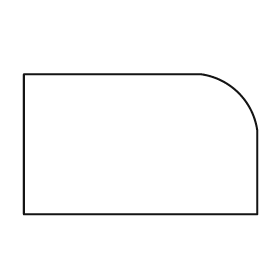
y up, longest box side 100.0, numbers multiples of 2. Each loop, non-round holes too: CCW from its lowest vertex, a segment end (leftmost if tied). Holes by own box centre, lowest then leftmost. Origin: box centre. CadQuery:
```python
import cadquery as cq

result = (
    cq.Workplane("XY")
    .moveTo(-50.0, -30.0)
    .lineTo(50.0, -30.0)
    .lineTo(50.0, 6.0)
    .threePointArc((42.0, 22.0), (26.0, 30.0))
    .lineTo(-50.0, 30.0)
    .close()
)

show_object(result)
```